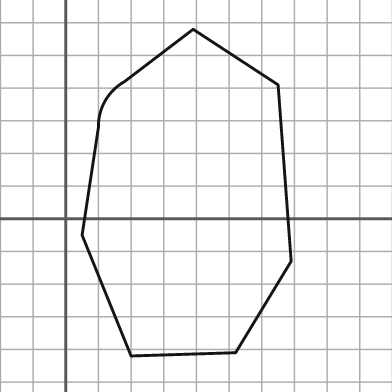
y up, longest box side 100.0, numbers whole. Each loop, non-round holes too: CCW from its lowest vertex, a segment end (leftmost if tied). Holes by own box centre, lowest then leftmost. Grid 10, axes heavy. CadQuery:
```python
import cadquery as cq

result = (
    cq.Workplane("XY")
    .moveTo(20.0, -42.0)
    .lineTo(52.0, -41.0)
    .lineTo(69.0, -13.0)
    .lineTo(65.0, 41.0)
    .lineTo(39.0, 58.0)
    .lineTo(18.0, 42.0)
    .threePointArc((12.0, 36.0), (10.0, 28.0))
    .lineTo(5.0, -5.0)
    .close()
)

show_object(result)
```